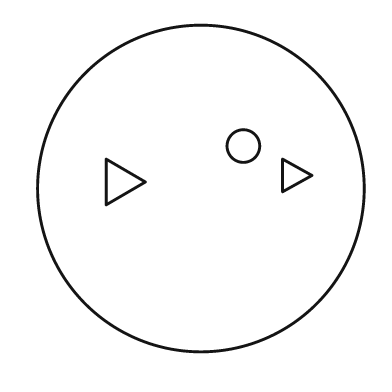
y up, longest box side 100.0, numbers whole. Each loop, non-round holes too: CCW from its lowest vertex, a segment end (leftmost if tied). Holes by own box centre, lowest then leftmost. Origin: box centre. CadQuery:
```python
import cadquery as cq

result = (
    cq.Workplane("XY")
    .moveTo(0.0, 0.0)
    .circle(50.0)
    .moveTo(-29.0, -5.0)
    .lineTo(-17.0, 2.0)
    .lineTo(-29.0, 9.0)
    .close()
    .moveTo(25.0, -1.0)
    .lineTo(34.0, 4.0)
    .lineTo(25.0, 9.0)
    .close()
    .moveTo(13.0, 13.0)
    .circle(5.0)
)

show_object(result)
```